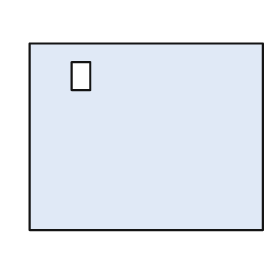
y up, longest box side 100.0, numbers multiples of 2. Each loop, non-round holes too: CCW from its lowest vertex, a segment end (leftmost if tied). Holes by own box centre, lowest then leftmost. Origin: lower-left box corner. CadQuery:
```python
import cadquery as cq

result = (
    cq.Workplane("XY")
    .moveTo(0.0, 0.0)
    .lineTo(100.0, 0.0)
    .lineTo(100.0, 80.0)
    .lineTo(0.0, 80.0)
    .close()
    .moveTo(18.0, 60.0)
    .lineTo(26.0, 60.0)
    .lineTo(26.0, 72.0)
    .lineTo(18.0, 72.0)
    .close()
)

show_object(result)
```